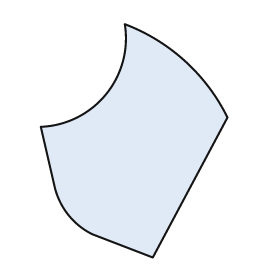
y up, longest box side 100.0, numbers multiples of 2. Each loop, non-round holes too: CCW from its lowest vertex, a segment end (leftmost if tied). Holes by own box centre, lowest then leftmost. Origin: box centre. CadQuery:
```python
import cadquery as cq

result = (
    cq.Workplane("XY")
    .moveTo(8.0, -50.0)
    .lineTo(40.0, 10.0)
    .threePointArc((22.0, 34.0), (-4.0, 50.0))
    .threePointArc((-12.0, 20.0), (-40.0, 6.0))
    .lineTo(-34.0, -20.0)
    .threePointArc((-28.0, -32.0), (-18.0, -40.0))
    .close()
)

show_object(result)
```